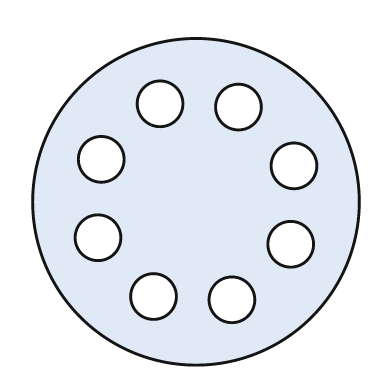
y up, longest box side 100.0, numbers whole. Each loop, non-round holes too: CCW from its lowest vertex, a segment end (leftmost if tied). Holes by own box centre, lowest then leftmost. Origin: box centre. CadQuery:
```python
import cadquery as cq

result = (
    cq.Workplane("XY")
    .moveTo(0.0, 0.0)
    .circle(50.0)
    .moveTo(11.0, -30.0)
    .circle(7.0)
    .moveTo(-13.0, -29.0)
    .circle(7.0)
    .moveTo(29.0, -13.0)
    .circle(7.0)
    .moveTo(-30.0, -11.0)
    .circle(7.0)
    .moveTo(30.0, 11.0)
    .circle(7.0)
    .moveTo(-29.0, 13.0)
    .circle(7.0)
    .moveTo(13.0, 29.0)
    .circle(7.0)
    .moveTo(-11.0, 30.0)
    .circle(7.0)
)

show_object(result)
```